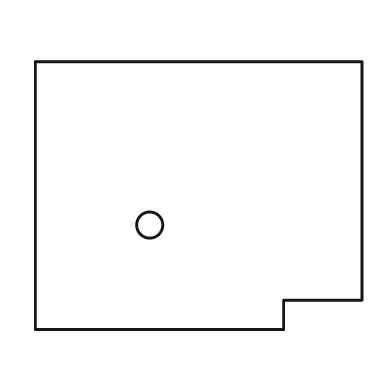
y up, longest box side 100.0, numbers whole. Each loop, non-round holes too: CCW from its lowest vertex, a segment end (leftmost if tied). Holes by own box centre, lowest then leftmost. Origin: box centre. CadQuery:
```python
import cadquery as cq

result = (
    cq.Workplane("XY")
    .moveTo(-50.0, -41.0)
    .lineTo(26.0, -41.0)
    .lineTo(26.0, -32.0)
    .lineTo(50.0, -32.0)
    .lineTo(50.0, 41.0)
    .lineTo(-50.0, 41.0)
    .close()
    .moveTo(-15.0, -9.0)
    .circle(4.0)
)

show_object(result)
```